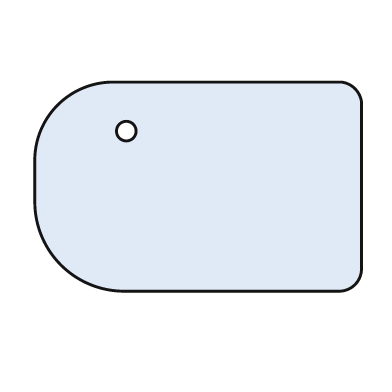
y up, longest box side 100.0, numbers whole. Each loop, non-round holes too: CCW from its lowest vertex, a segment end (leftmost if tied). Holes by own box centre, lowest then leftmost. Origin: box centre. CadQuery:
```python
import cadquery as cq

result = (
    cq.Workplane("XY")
    .moveTo(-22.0, -32.0)
    .lineTo(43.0, -32.0)
    .threePointArc((48.0, -30.0), (50.0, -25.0))
    .lineTo(50.0, 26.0)
    .threePointArc((48.0, 30.0), (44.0, 32.0))
    .lineTo(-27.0, 32.0)
    .threePointArc((-43.0, 25.0), (-50.0, 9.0))
    .lineTo(-50.0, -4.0)
    .threePointArc((-42.0, -24.0), (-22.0, -32.0))
    .close()
    .moveTo(-22.0, 17.0)
    .circle(3.0)
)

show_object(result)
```